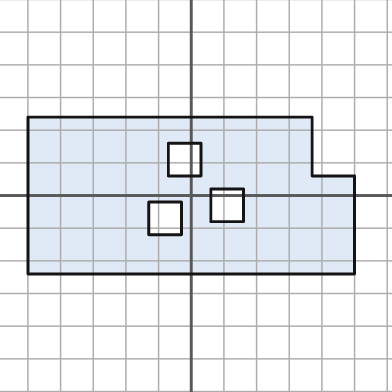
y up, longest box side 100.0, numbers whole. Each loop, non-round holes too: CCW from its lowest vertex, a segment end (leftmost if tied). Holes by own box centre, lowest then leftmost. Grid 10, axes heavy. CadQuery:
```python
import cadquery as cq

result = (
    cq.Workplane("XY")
    .moveTo(-50.0, -24.0)
    .lineTo(50.0, -24.0)
    .lineTo(50.0, 6.0)
    .lineTo(37.0, 6.0)
    .lineTo(37.0, 24.0)
    .lineTo(-50.0, 24.0)
    .close()
    .moveTo(-13.0, -12.0)
    .lineTo(-3.0, -12.0)
    .lineTo(-3.0, -2.0)
    .lineTo(-13.0, -2.0)
    .close()
    .moveTo(6.0, -8.0)
    .lineTo(16.0, -8.0)
    .lineTo(16.0, 2.0)
    .lineTo(6.0, 2.0)
    .close()
    .moveTo(-7.0, 6.0)
    .lineTo(3.0, 6.0)
    .lineTo(3.0, 16.0)
    .lineTo(-7.0, 16.0)
    .close()
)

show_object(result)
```